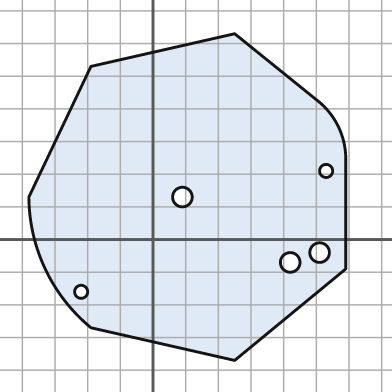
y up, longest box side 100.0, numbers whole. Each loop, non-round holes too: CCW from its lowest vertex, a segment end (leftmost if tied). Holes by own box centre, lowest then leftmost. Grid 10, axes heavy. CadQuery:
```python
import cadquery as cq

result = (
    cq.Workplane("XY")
    .moveTo(25.0, -37.0)
    .lineTo(59.0, -9.0)
    .lineTo(59.0, 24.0)
    .threePointArc((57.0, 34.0), (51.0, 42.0))
    .lineTo(25.0, 63.0)
    .lineTo(-19.0, 53.0)
    .lineTo(-38.0, 13.0)
    .threePointArc((-33.0, -9.0), (-19.0, -27.0))
    .close()
    .moveTo(-22.0, -16.0)
    .circle(2.0)
    .moveTo(42.0, -7.0)
    .circle(3.0)
    .moveTo(51.0, -4.0)
    .circle(3.0)
    .moveTo(9.0, 13.0)
    .circle(3.0)
    .moveTo(53.0, 21.0)
    .circle(2.0)
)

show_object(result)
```